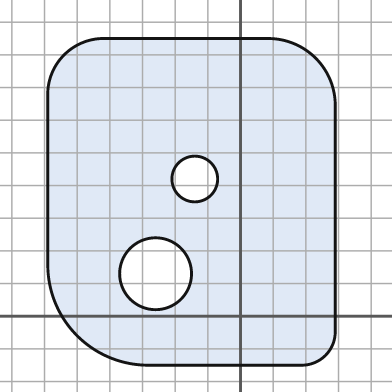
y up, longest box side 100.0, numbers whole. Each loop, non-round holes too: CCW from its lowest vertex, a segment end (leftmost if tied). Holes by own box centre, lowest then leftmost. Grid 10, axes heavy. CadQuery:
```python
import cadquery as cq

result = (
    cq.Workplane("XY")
    .moveTo(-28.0, -15.0)
    .lineTo(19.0, -15.0)
    .threePointArc((26.0, -12.0), (29.0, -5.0))
    .lineTo(29.0, 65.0)
    .threePointArc((23.0, 79.0), (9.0, 85.0))
    .lineTo(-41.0, 85.0)
    .threePointArc((-54.0, 80.0), (-59.0, 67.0))
    .lineTo(-59.0, 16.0)
    .threePointArc((-50.0, -6.0), (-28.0, -15.0))
    .close()
    .moveTo(-26.0, 13.0)
    .circle(11.0)
    .moveTo(-14.0, 42.0)
    .circle(7.0)
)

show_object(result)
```